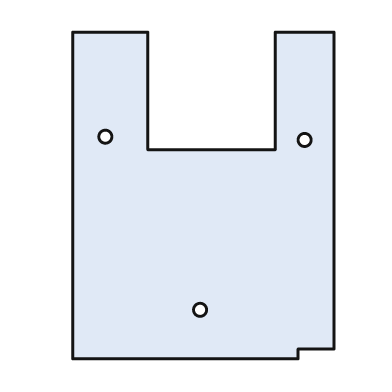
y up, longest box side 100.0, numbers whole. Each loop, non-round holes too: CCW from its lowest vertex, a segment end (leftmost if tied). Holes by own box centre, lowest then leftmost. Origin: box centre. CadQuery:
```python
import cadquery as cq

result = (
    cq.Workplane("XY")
    .moveTo(-40.0, -50.0)
    .lineTo(29.0, -50.0)
    .lineTo(29.0, -47.0)
    .lineTo(40.0, -47.0)
    .lineTo(40.0, 50.0)
    .lineTo(22.0, 50.0)
    .lineTo(22.0, 14.0)
    .lineTo(-17.0, 14.0)
    .lineTo(-17.0, 50.0)
    .lineTo(-40.0, 50.0)
    .close()
    .moveTo(-1.0, -35.0)
    .circle(2.0)
    .moveTo(31.0, 17.0)
    .circle(2.0)
    .moveTo(-30.0, 18.0)
    .circle(2.0)
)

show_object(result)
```